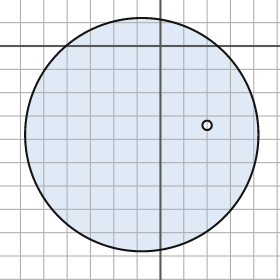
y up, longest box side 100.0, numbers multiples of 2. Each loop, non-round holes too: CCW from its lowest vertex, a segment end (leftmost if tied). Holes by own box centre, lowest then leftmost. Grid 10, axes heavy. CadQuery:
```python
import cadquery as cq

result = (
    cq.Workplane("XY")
    .moveTo(-8.0, -38.0)
    .circle(50.0)
    .moveTo(20.0, -34.0)
    .circle(2.0)
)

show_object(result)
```